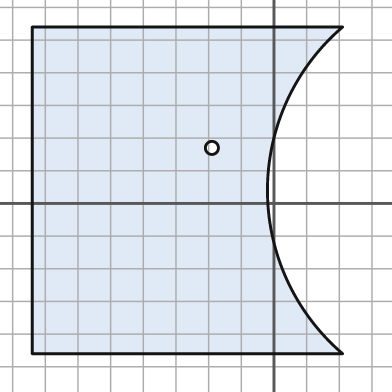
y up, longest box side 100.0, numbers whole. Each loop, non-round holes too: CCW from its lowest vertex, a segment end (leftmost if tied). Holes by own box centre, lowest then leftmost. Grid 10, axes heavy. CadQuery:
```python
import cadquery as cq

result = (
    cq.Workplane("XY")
    .moveTo(-74.0, -46.0)
    .lineTo(21.0, -46.0)
    .threePointArc((-2.0, 4.0), (21.0, 54.0))
    .lineTo(-74.0, 54.0)
    .close()
    .moveTo(-19.0, 17.0)
    .circle(2.0)
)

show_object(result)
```